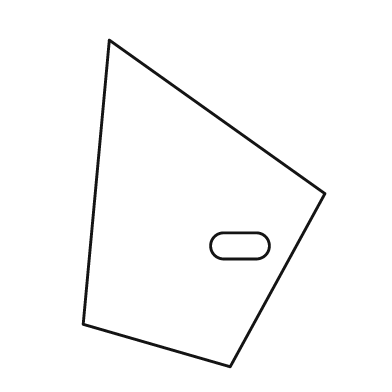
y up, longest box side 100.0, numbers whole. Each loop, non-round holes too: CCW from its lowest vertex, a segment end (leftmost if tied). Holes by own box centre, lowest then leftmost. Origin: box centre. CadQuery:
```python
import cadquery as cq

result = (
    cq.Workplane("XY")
    .moveTo(8.0, -50.0)
    .lineTo(37.0, 3.0)
    .lineTo(-29.0, 50.0)
    .lineTo(-37.0, -37.0)
    .close()
    .moveTo(6.0, -17.0)
    .lineTo(16.0, -17.0)
    .threePointArc((20.0, -13.0), (16.0, -9.0))
    .lineTo(6.0, -9.0)
    .threePointArc((2.0, -13.0), (6.0, -17.0))
    .close()
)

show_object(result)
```